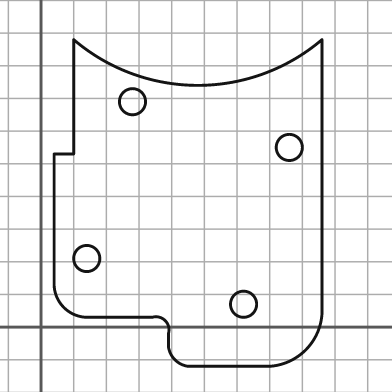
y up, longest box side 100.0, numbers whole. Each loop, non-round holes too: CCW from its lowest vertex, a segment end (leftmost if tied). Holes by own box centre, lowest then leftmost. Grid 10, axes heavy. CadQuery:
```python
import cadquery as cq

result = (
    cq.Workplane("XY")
    .moveTo(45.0, -12.0)
    .lineTo(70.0, -12.0)
    .threePointArc((81.0, -7.0), (86.0, 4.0))
    .lineTo(86.0, 88.0)
    .threePointArc((48.0, 74.0), (10.0, 88.0))
    .lineTo(10.0, 53.0)
    .lineTo(4.0, 53.0)
    .lineTo(4.0, 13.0)
    .threePointArc((7.0, 6.0), (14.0, 3.0))
    .lineTo(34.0, 3.0)
    .threePointArc((38.0, 2.0), (39.0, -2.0))
    .lineTo(39.0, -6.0)
    .threePointArc((41.0, -10.0), (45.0, -12.0))
    .close()
    .moveTo(62.0, 7.0)
    .circle(4.0)
    .moveTo(14.0, 21.0)
    .circle(4.0)
    .moveTo(76.0, 55.0)
    .circle(4.0)
    .moveTo(28.0, 69.0)
    .circle(4.0)
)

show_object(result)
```